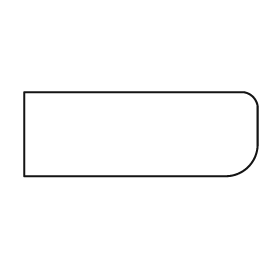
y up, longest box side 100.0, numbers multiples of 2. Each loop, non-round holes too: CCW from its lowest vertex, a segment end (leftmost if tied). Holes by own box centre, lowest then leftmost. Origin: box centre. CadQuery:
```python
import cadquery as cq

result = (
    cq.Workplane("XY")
    .moveTo(-50.0, -18.0)
    .lineTo(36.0, -18.0)
    .threePointArc((46.0, -14.0), (50.0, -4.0))
    .lineTo(50.0, 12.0)
    .threePointArc((48.0, 16.0), (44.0, 18.0))
    .lineTo(-50.0, 18.0)
    .close()
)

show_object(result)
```